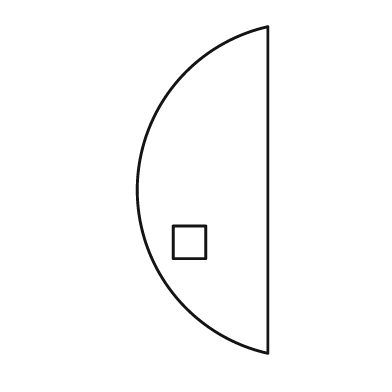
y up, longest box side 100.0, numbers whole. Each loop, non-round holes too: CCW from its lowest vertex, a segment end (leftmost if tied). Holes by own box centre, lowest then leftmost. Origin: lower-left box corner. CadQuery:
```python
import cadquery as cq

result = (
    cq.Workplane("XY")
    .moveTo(40.0, 0.0)
    .lineTo(40.0, 100.0)
    .threePointArc((0.0, 50.0), (40.0, 0.0))
    .close()
    .moveTo(11.0, 29.0)
    .lineTo(21.0, 29.0)
    .lineTo(21.0, 39.0)
    .lineTo(11.0, 39.0)
    .close()
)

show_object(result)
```